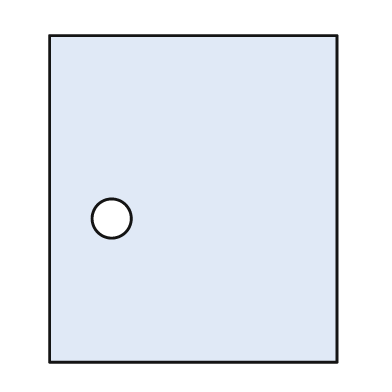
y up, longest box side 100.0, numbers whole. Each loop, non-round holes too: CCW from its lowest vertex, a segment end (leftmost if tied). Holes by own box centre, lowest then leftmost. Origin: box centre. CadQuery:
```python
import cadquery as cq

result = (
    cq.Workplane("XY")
    .moveTo(-44.0, -50.0)
    .lineTo(44.0, -50.0)
    .lineTo(44.0, 50.0)
    .lineTo(-44.0, 50.0)
    .close()
    .moveTo(-25.0, -6.0)
    .circle(6.0)
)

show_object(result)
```